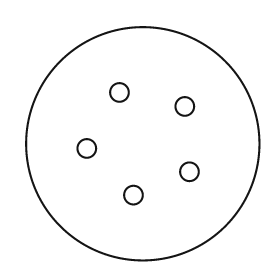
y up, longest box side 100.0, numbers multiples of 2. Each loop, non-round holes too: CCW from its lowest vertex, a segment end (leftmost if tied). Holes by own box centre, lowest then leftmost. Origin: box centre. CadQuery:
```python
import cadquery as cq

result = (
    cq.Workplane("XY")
    .moveTo(0.0, 0.0)
    .circle(50.0)
    .moveTo(-4.0, -22.0)
    .circle(4.0)
    .moveTo(20.0, -12.0)
    .circle(4.0)
    .moveTo(-24.0, -2.0)
    .circle(4.0)
    .moveTo(18.0, 16.0)
    .circle(4.0)
    .moveTo(-10.0, 22.0)
    .circle(4.0)
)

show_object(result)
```